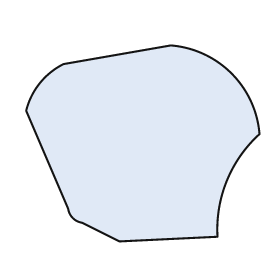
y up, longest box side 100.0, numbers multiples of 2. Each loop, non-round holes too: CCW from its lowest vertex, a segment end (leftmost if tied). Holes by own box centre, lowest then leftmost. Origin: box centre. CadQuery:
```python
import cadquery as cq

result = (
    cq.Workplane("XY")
    .moveTo(-10.0, -42.0)
    .lineTo(32.0, -40.0)
    .threePointArc((36.0, -16.0), (50.0, 4.0))
    .threePointArc((38.0, 30.0), (12.0, 42.0))
    .lineTo(-34.0, 34.0)
    .threePointArc((-44.0, 26.0), (-50.0, 14.0))
    .lineTo(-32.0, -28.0)
    .threePointArc((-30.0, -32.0), (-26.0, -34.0))
    .close()
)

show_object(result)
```